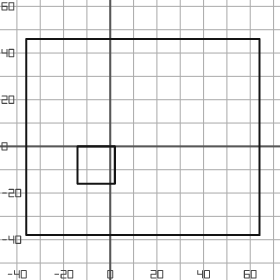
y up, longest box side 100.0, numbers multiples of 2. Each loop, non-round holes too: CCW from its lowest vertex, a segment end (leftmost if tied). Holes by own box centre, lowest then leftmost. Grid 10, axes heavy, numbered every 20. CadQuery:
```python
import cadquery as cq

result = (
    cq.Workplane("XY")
    .moveTo(-36.0, -38.0)
    .lineTo(64.0, -38.0)
    .lineTo(64.0, 46.0)
    .lineTo(-36.0, 46.0)
    .close()
    .moveTo(-14.0, -16.0)
    .lineTo(2.0, -16.0)
    .lineTo(2.0, 0.0)
    .lineTo(-14.0, 0.0)
    .close()
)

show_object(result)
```